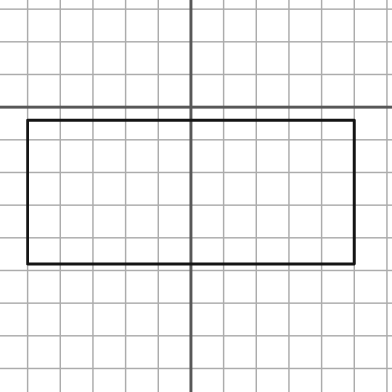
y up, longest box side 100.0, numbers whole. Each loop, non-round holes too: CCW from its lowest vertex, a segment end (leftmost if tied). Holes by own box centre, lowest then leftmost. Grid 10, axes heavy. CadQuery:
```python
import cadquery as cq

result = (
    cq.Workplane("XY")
    .moveTo(-50.0, -48.0)
    .lineTo(50.0, -48.0)
    .lineTo(50.0, -4.0)
    .lineTo(-50.0, -4.0)
    .close()
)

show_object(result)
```